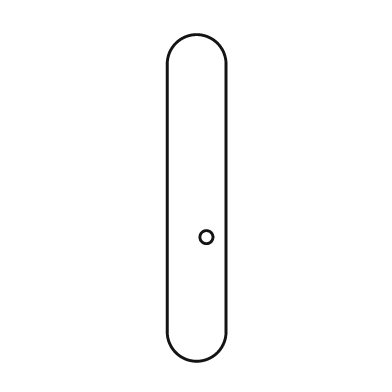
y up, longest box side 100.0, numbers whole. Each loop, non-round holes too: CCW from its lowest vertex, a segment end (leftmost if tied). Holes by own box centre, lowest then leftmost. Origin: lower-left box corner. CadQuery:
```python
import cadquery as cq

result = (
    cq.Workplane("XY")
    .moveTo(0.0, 9.0)
    .threePointArc((9.0, 0.0), (18.0, 9.0))
    .lineTo(18.0, 91.0)
    .threePointArc((9.0, 100.0), (0.0, 91.0))
    .close()
    .moveTo(12.0, 38.0)
    .circle(2.0)
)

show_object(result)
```